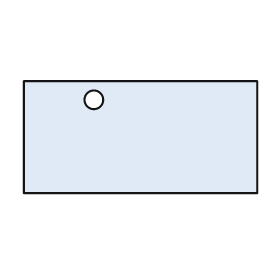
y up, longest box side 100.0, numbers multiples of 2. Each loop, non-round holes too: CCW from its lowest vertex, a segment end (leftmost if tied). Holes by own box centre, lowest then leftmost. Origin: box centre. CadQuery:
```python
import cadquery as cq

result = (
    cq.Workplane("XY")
    .moveTo(-50.0, -24.0)
    .lineTo(50.0, -24.0)
    .lineTo(50.0, 24.0)
    .lineTo(-50.0, 24.0)
    .close()
    .moveTo(-20.0, 16.0)
    .circle(4.0)
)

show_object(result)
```